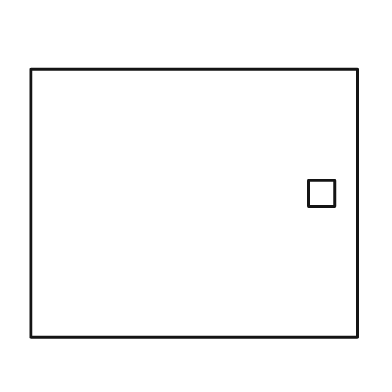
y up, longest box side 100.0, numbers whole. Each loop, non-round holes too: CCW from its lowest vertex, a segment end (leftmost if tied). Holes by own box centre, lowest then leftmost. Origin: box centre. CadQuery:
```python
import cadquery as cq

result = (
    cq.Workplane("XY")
    .moveTo(-50.0, -41.0)
    .lineTo(50.0, -41.0)
    .lineTo(50.0, 41.0)
    .lineTo(-50.0, 41.0)
    .close()
    .moveTo(35.0, -1.0)
    .lineTo(43.0, -1.0)
    .lineTo(43.0, 7.0)
    .lineTo(35.0, 7.0)
    .close()
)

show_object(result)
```